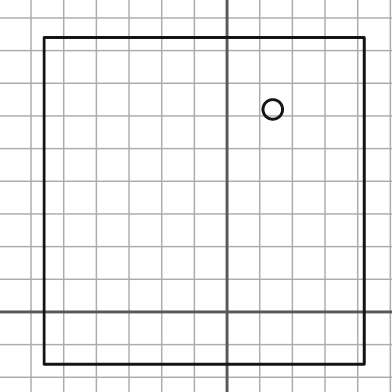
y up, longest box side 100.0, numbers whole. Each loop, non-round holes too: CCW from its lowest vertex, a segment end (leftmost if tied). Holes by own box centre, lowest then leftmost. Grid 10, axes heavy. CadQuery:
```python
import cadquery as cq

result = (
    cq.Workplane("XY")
    .moveTo(-56.0, -16.0)
    .lineTo(42.0, -16.0)
    .lineTo(42.0, 84.0)
    .lineTo(-56.0, 84.0)
    .close()
    .moveTo(14.0, 62.0)
    .circle(3.0)
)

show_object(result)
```